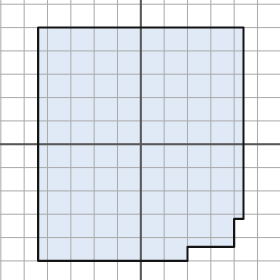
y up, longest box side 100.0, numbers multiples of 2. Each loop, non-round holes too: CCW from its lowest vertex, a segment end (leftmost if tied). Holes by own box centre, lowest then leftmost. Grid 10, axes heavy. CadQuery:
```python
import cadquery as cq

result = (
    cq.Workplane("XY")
    .moveTo(-44.0, -50.0)
    .lineTo(20.0, -50.0)
    .lineTo(20.0, -44.0)
    .lineTo(40.0, -44.0)
    .lineTo(40.0, -32.0)
    .lineTo(44.0, -32.0)
    .lineTo(44.0, 50.0)
    .lineTo(-44.0, 50.0)
    .close()
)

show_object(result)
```